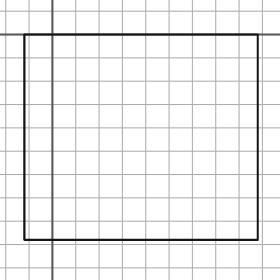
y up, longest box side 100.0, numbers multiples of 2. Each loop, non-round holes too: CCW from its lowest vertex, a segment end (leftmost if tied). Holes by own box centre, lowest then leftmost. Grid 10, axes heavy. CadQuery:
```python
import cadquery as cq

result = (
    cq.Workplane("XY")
    .moveTo(-12.0, -88.0)
    .lineTo(88.0, -88.0)
    .lineTo(88.0, 0.0)
    .lineTo(-12.0, 0.0)
    .close()
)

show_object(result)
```